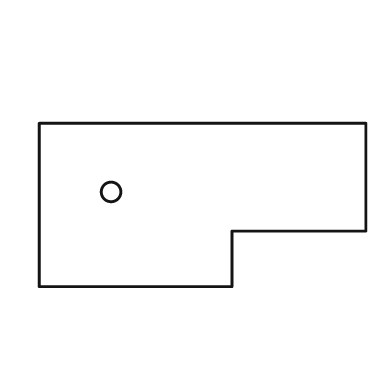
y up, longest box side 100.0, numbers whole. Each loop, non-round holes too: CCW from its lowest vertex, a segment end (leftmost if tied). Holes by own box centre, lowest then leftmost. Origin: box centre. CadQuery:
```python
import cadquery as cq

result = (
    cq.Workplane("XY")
    .moveTo(-50.0, -25.0)
    .lineTo(9.0, -25.0)
    .lineTo(9.0, -8.0)
    .lineTo(50.0, -8.0)
    .lineTo(50.0, 25.0)
    .lineTo(-50.0, 25.0)
    .close()
    .moveTo(-28.0, 4.0)
    .circle(3.0)
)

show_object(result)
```